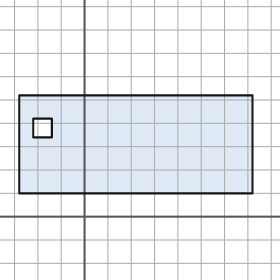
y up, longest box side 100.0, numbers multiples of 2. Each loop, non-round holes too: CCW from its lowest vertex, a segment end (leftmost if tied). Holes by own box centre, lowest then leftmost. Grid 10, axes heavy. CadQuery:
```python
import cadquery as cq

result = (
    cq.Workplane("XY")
    .moveTo(-28.0, 10.0)
    .lineTo(72.0, 10.0)
    .lineTo(72.0, 52.0)
    .lineTo(-28.0, 52.0)
    .close()
    .moveTo(-22.0, 34.0)
    .lineTo(-14.0, 34.0)
    .lineTo(-14.0, 42.0)
    .lineTo(-22.0, 42.0)
    .close()
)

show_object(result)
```